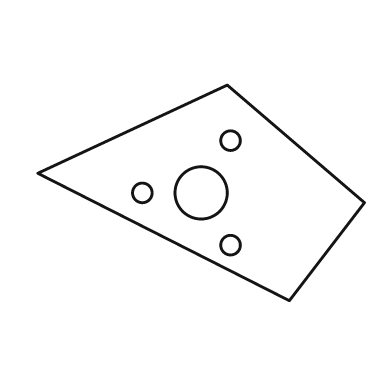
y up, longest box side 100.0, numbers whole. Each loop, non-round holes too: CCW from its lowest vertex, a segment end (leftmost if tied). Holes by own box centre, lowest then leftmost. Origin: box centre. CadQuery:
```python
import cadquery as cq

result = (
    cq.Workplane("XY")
    .moveTo(27.0, -33.0)
    .lineTo(50.0, -3.0)
    .lineTo(8.0, 33.0)
    .lineTo(-50.0, 6.0)
    .close()
    .moveTo(9.0, -16.0)
    .circle(3.0)
    .moveTo(-18.0, 0.0)
    .circle(3.0)
    .moveTo(0.0, 0.0)
    .circle(8.0)
    .moveTo(9.0, 16.0)
    .circle(3.0)
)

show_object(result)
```